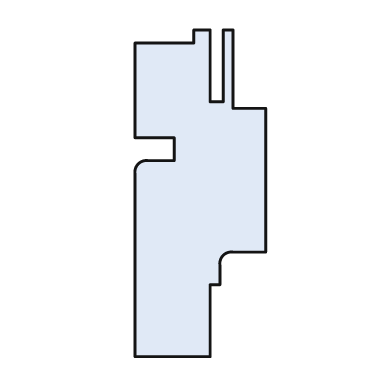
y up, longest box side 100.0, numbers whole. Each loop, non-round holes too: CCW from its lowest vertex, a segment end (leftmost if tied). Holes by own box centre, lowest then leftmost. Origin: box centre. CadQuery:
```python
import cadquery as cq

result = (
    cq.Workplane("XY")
    .moveTo(-20.0, -50.0)
    .lineTo(3.0, -50.0)
    .lineTo(3.0, -28.0)
    .lineTo(6.0, -28.0)
    .lineTo(6.0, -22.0)
    .threePointArc((7.0, -19.0), (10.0, -18.0))
    .lineTo(20.0, -18.0)
    .lineTo(20.0, 26.0)
    .lineTo(10.0, 26.0)
    .lineTo(10.0, 50.0)
    .lineTo(7.0, 50.0)
    .lineTo(7.0, 28.0)
    .lineTo(3.0, 28.0)
    .lineTo(3.0, 50.0)
    .lineTo(-2.0, 50.0)
    .lineTo(-2.0, 46.0)
    .lineTo(-20.0, 46.0)
    .lineTo(-20.0, 17.0)
    .lineTo(-8.0, 17.0)
    .lineTo(-8.0, 10.0)
    .lineTo(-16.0, 10.0)
    .threePointArc((-19.0, 9.0), (-20.0, 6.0))
    .close()
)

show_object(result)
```